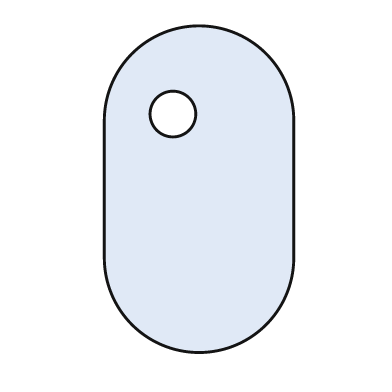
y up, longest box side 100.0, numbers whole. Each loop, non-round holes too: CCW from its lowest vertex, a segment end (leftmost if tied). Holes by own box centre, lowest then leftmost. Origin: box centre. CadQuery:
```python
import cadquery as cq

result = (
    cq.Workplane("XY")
    .moveTo(-29.0, -21.0)
    .threePointArc((0.0, -50.0), (29.0, -21.0))
    .lineTo(29.0, 21.0)
    .threePointArc((0.0, 50.0), (-29.0, 21.0))
    .close()
    .moveTo(-8.0, 23.0)
    .circle(7.0)
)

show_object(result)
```